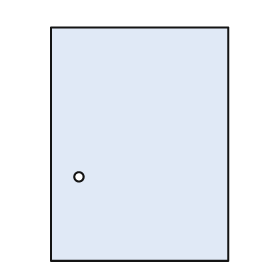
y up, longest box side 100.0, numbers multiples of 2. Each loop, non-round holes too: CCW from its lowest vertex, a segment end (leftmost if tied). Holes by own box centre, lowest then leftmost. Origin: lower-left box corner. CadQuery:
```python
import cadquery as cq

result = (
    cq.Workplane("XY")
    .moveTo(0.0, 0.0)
    .lineTo(76.0, 0.0)
    .lineTo(76.0, 100.0)
    .lineTo(0.0, 100.0)
    .close()
    .moveTo(12.0, 36.0)
    .circle(2.0)
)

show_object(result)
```